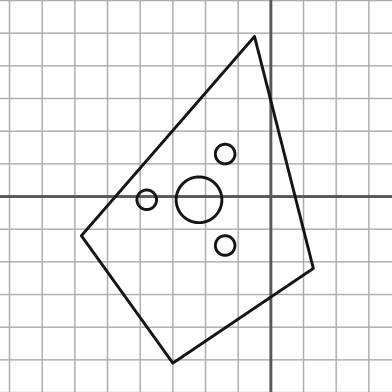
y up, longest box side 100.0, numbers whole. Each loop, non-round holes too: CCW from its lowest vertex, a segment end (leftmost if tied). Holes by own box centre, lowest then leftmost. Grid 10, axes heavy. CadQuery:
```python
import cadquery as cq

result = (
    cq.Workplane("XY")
    .moveTo(-30.0, -51.0)
    .lineTo(13.0, -22.0)
    .lineTo(-5.0, 49.0)
    .lineTo(-58.0, -12.0)
    .close()
    .moveTo(-14.0, -15.0)
    .circle(3.0)
    .moveTo(-38.0, -1.0)
    .circle(3.0)
    .moveTo(-22.0, -1.0)
    .circle(7.0)
    .moveTo(-14.0, 13.0)
    .circle(3.0)
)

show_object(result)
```